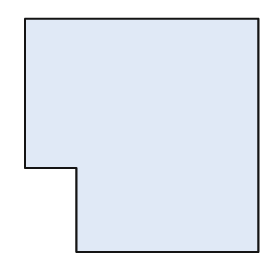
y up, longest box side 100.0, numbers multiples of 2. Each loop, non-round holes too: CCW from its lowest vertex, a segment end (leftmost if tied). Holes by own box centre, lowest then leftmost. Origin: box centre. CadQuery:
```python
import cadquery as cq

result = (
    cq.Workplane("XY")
    .moveTo(-28.0, -50.0)
    .lineTo(50.0, -50.0)
    .lineTo(50.0, 50.0)
    .lineTo(-50.0, 50.0)
    .lineTo(-50.0, -14.0)
    .lineTo(-28.0, -14.0)
    .close()
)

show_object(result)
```